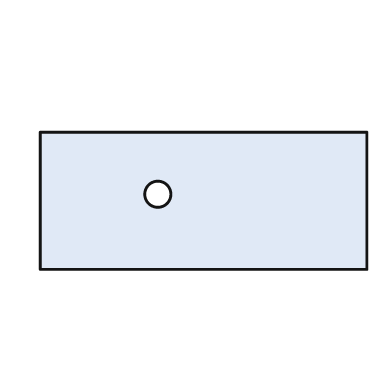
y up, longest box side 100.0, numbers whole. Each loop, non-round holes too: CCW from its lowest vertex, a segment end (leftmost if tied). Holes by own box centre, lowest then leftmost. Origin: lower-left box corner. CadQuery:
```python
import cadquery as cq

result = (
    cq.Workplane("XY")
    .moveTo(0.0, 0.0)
    .lineTo(100.0, 0.0)
    .lineTo(100.0, 42.0)
    .lineTo(0.0, 42.0)
    .close()
    .moveTo(36.0, 23.0)
    .circle(4.0)
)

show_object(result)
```